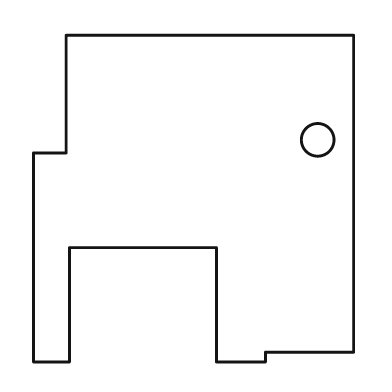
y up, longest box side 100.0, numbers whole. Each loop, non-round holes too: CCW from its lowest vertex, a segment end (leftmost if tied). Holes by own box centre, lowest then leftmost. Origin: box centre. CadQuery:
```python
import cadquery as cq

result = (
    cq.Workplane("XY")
    .moveTo(-49.0, -50.0)
    .lineTo(-38.0, -50.0)
    .lineTo(-38.0, -15.0)
    .lineTo(7.0, -15.0)
    .lineTo(7.0, -50.0)
    .lineTo(22.0, -50.0)
    .lineTo(22.0, -47.0)
    .lineTo(49.0, -47.0)
    .lineTo(49.0, 50.0)
    .lineTo(-39.0, 50.0)
    .lineTo(-39.0, 14.0)
    .lineTo(-49.0, 14.0)
    .close()
    .moveTo(38.0, 18.0)
    .circle(5.0)
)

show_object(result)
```